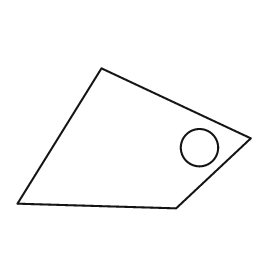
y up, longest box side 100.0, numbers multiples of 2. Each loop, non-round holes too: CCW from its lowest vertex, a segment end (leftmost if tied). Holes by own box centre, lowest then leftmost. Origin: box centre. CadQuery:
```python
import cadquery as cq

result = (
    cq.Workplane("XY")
    .moveTo(18.0, -30.0)
    .lineTo(50.0, 0.0)
    .lineTo(-14.0, 30.0)
    .lineTo(-50.0, -28.0)
    .close()
    .moveTo(28.0, -4.0)
    .circle(8.0)
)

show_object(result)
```